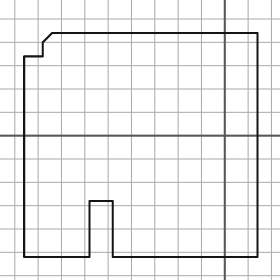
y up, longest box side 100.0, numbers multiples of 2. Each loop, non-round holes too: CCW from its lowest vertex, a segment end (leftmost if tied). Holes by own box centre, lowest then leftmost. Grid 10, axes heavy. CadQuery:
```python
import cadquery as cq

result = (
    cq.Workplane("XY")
    .moveTo(-86.0, -52.0)
    .lineTo(-58.0, -52.0)
    .lineTo(-58.0, -28.0)
    .lineTo(-48.0, -28.0)
    .lineTo(-48.0, -52.0)
    .lineTo(14.0, -52.0)
    .lineTo(14.0, 44.0)
    .lineTo(-74.0, 44.0)
    .lineTo(-78.0, 40.0)
    .lineTo(-78.0, 34.0)
    .lineTo(-86.0, 34.0)
    .close()
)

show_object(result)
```